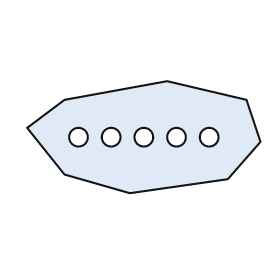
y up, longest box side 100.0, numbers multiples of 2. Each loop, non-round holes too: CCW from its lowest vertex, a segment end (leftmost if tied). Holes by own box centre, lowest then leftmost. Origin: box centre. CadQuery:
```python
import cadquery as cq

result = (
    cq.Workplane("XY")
    .moveTo(-6.0, -24.0)
    .lineTo(36.0, -18.0)
    .lineTo(50.0, -2.0)
    .lineTo(44.0, 16.0)
    .lineTo(10.0, 24.0)
    .lineTo(-34.0, 16.0)
    .lineTo(-50.0, 4.0)
    .lineTo(-34.0, -16.0)
    .close()
    .moveTo(-28.0, 0.0)
    .circle(4.0)
    .moveTo(-14.0, 0.0)
    .circle(4.0)
    .moveTo(0.0, 0.0)
    .circle(4.0)
    .moveTo(14.0, 0.0)
    .circle(4.0)
    .moveTo(28.0, 0.0)
    .circle(4.0)
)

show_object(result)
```